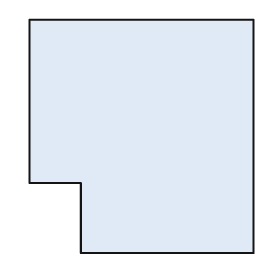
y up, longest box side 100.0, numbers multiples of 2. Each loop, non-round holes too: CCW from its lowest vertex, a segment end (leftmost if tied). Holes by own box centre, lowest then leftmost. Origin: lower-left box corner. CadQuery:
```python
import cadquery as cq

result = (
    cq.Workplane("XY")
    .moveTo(22.0, 0.0)
    .lineTo(96.0, 0.0)
    .lineTo(96.0, 100.0)
    .lineTo(0.0, 100.0)
    .lineTo(0.0, 30.0)
    .lineTo(22.0, 30.0)
    .close()
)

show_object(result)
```